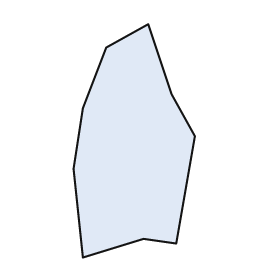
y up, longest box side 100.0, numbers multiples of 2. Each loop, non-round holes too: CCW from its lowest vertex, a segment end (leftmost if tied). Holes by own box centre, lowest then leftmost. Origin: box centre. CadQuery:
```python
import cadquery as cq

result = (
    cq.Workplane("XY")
    .moveTo(-22.0, -50.0)
    .lineTo(4.0, -42.0)
    .lineTo(18.0, -44.0)
    .lineTo(26.0, 2.0)
    .lineTo(16.0, 20.0)
    .lineTo(6.0, 50.0)
    .lineTo(-12.0, 40.0)
    .lineTo(-22.0, 14.0)
    .lineTo(-26.0, -12.0)
    .close()
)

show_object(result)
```